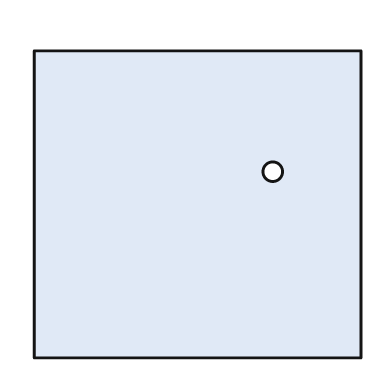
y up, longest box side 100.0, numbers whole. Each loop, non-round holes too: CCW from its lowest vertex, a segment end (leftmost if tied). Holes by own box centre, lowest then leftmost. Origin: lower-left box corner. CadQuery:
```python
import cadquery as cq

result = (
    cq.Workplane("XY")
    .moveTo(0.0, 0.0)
    .lineTo(100.0, 0.0)
    .lineTo(100.0, 94.0)
    .lineTo(0.0, 94.0)
    .close()
    .moveTo(73.0, 57.0)
    .circle(3.0)
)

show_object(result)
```